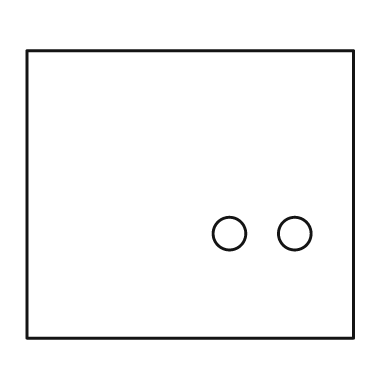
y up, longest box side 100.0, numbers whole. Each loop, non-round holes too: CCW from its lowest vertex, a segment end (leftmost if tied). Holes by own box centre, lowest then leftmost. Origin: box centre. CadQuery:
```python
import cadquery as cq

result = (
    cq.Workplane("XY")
    .moveTo(-50.0, -44.0)
    .lineTo(50.0, -44.0)
    .lineTo(50.0, 44.0)
    .lineTo(-50.0, 44.0)
    .close()
    .moveTo(12.0, -12.0)
    .circle(5.0)
    .moveTo(32.0, -12.0)
    .circle(5.0)
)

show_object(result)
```